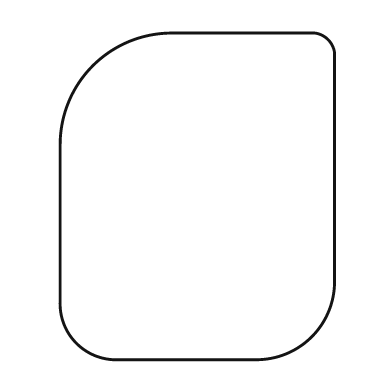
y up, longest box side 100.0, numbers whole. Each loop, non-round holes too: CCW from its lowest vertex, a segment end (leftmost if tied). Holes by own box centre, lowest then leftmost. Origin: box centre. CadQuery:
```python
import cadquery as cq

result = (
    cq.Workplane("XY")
    .moveTo(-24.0, -50.0)
    .lineTo(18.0, -50.0)
    .threePointArc((35.0, -43.0), (42.0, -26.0))
    .lineTo(42.0, 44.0)
    .threePointArc((40.0, 48.0), (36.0, 50.0))
    .lineTo(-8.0, 50.0)
    .threePointArc((-32.0, 40.0), (-42.0, 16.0))
    .lineTo(-42.0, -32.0)
    .threePointArc((-37.0, -45.0), (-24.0, -50.0))
    .close()
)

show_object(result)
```